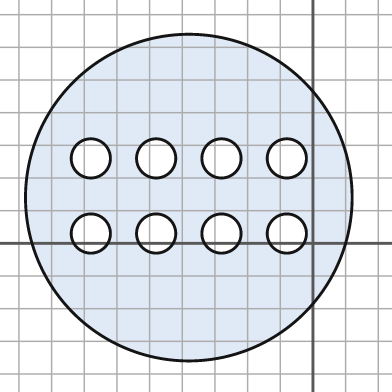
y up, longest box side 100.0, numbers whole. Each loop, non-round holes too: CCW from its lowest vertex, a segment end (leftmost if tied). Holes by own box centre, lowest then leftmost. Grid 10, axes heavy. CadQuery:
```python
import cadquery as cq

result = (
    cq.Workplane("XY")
    .moveTo(-38.0, 14.0)
    .circle(50.0)
    .moveTo(-68.0, 3.0)
    .circle(6.0)
    .moveTo(-48.0, 3.0)
    .circle(6.0)
    .moveTo(-28.0, 3.0)
    .circle(6.0)
    .moveTo(-8.0, 3.0)
    .circle(6.0)
    .moveTo(-68.0, 26.0)
    .circle(6.0)
    .moveTo(-48.0, 26.0)
    .circle(6.0)
    .moveTo(-28.0, 26.0)
    .circle(6.0)
    .moveTo(-8.0, 26.0)
    .circle(6.0)
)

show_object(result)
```